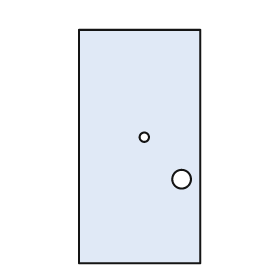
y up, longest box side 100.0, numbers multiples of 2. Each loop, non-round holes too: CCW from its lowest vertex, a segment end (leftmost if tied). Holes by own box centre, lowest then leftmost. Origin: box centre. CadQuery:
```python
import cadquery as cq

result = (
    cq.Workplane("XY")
    .moveTo(-26.0, -50.0)
    .lineTo(26.0, -50.0)
    .lineTo(26.0, 50.0)
    .lineTo(-26.0, 50.0)
    .close()
    .moveTo(18.0, -14.0)
    .circle(4.0)
    .moveTo(2.0, 4.0)
    .circle(2.0)
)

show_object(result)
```